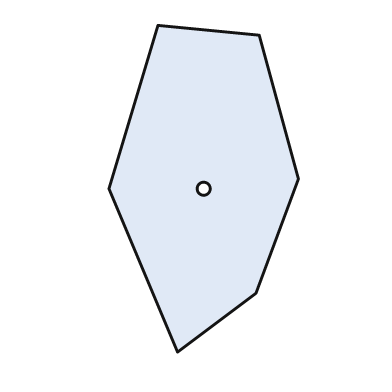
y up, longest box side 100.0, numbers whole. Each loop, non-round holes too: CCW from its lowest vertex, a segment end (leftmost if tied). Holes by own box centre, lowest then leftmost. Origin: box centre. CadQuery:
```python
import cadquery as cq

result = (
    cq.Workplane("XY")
    .moveTo(-8.0, -50.0)
    .lineTo(16.0, -32.0)
    .lineTo(29.0, 3.0)
    .lineTo(17.0, 47.0)
    .lineTo(-14.0, 50.0)
    .lineTo(-29.0, 0.0)
    .close()
    .moveTo(0.0, 0.0)
    .circle(2.0)
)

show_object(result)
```